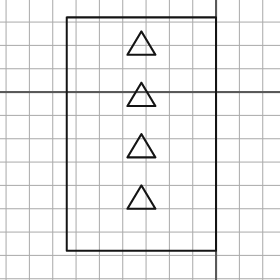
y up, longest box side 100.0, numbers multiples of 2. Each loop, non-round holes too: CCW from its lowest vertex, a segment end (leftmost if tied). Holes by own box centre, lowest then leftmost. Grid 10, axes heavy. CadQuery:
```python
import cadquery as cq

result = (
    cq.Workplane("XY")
    .moveTo(-64.0, -68.0)
    .lineTo(0.0, -68.0)
    .lineTo(0.0, 32.0)
    .lineTo(-64.0, 32.0)
    .close()
    .moveTo(-38.0, -50.0)
    .lineTo(-26.0, -50.0)
    .lineTo(-32.0, -40.0)
    .close()
    .moveTo(-38.0, -28.0)
    .lineTo(-26.0, -28.0)
    .lineTo(-32.0, -18.0)
    .close()
    .moveTo(-38.0, -6.0)
    .lineTo(-26.0, -6.0)
    .lineTo(-32.0, 4.0)
    .close()
    .moveTo(-38.0, 16.0)
    .lineTo(-26.0, 16.0)
    .lineTo(-32.0, 26.0)
    .close()
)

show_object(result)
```